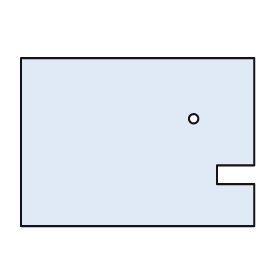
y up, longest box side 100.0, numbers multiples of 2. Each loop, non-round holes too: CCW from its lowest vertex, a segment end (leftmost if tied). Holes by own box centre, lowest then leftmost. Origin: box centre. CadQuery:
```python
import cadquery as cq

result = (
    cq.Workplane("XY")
    .moveTo(-50.0, -36.0)
    .lineTo(50.0, -36.0)
    .lineTo(50.0, -18.0)
    .lineTo(34.0, -18.0)
    .lineTo(34.0, -10.0)
    .lineTo(50.0, -10.0)
    .lineTo(50.0, 36.0)
    .lineTo(-50.0, 36.0)
    .close()
    .moveTo(24.0, 10.0)
    .circle(2.0)
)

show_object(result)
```